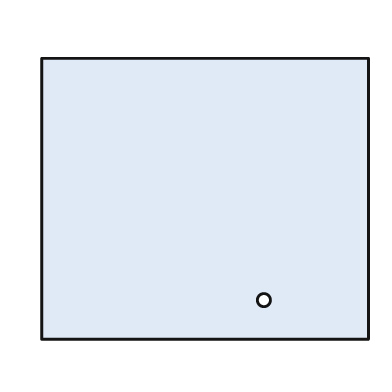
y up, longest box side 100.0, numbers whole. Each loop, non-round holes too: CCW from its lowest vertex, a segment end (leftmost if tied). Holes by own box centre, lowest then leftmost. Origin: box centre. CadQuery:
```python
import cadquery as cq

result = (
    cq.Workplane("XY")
    .moveTo(-50.0, -43.0)
    .lineTo(50.0, -43.0)
    .lineTo(50.0, 43.0)
    .lineTo(-50.0, 43.0)
    .close()
    .moveTo(18.0, -31.0)
    .circle(2.0)
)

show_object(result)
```